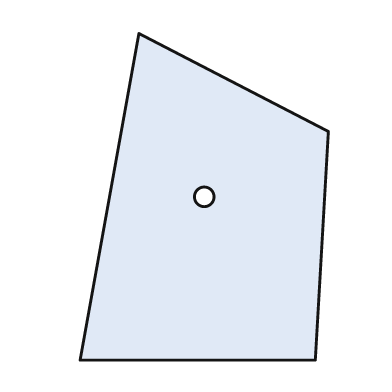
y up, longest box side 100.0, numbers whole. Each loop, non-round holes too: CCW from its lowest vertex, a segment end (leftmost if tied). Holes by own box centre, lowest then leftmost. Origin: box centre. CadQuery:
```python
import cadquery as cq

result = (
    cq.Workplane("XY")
    .moveTo(-38.0, -50.0)
    .lineTo(34.0, -50.0)
    .lineTo(38.0, 20.0)
    .lineTo(-20.0, 50.0)
    .close()
    .moveTo(0.0, 0.0)
    .circle(3.0)
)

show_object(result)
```